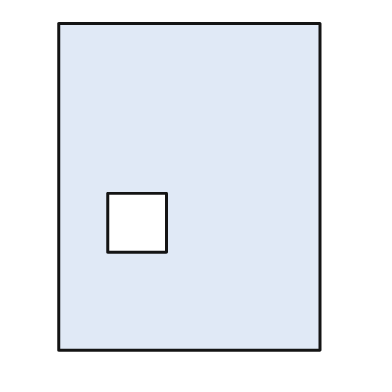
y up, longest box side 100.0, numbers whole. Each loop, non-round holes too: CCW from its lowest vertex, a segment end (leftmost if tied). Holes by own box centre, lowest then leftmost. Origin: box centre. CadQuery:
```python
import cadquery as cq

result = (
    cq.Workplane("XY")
    .moveTo(-40.0, -50.0)
    .lineTo(40.0, -50.0)
    .lineTo(40.0, 50.0)
    .lineTo(-40.0, 50.0)
    .close()
    .moveTo(-25.0, -20.0)
    .lineTo(-7.0, -20.0)
    .lineTo(-7.0, -2.0)
    .lineTo(-25.0, -2.0)
    .close()
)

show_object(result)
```